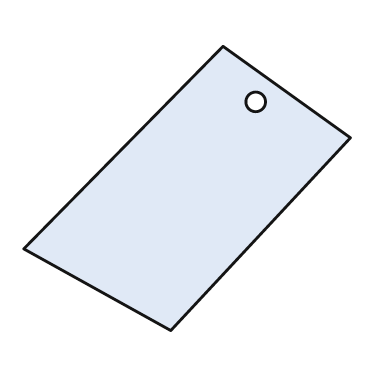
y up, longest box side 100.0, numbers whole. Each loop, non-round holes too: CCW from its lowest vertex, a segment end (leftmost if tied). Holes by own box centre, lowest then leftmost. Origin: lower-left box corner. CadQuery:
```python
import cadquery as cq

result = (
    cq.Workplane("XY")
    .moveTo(45.0, 0.0)
    .lineTo(100.0, 59.0)
    .lineTo(61.0, 87.0)
    .lineTo(0.0, 25.0)
    .close()
    .moveTo(71.0, 70.0)
    .circle(3.0)
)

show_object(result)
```